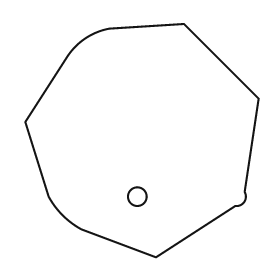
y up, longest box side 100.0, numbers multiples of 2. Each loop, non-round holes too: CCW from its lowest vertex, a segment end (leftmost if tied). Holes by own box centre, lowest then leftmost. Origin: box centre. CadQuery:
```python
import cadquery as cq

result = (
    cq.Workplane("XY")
    .moveTo(6.0, -50.0)
    .lineTo(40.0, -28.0)
    .threePointArc((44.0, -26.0), (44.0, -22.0))
    .lineTo(50.0, 18.0)
    .lineTo(18.0, 50.0)
    .lineTo(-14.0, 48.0)
    .threePointArc((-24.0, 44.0), (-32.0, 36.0))
    .lineTo(-50.0, 8.0)
    .lineTo(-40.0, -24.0)
    .threePointArc((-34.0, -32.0), (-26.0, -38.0))
    .close()
    .moveTo(-2.0, -24.0)
    .circle(4.0)
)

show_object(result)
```